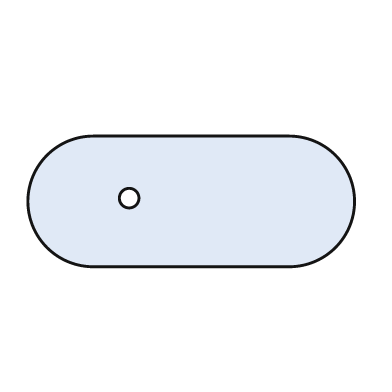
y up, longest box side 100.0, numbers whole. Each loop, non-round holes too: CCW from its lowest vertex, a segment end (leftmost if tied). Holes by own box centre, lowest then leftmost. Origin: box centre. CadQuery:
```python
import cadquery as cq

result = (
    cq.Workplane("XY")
    .moveTo(-30.0, -20.0)
    .lineTo(30.0, -20.0)
    .threePointArc((50.0, 0.0), (30.0, 20.0))
    .lineTo(-30.0, 20.0)
    .threePointArc((-50.0, 0.0), (-30.0, -20.0))
    .close()
    .moveTo(-19.0, 1.0)
    .circle(3.0)
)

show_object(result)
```